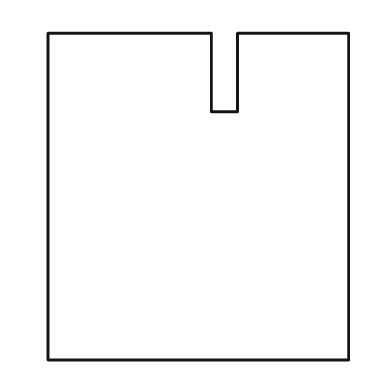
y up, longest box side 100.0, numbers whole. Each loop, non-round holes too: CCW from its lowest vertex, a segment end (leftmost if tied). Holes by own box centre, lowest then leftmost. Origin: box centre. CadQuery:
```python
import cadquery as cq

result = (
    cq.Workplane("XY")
    .moveTo(-46.0, -50.0)
    .lineTo(46.0, -50.0)
    .lineTo(46.0, 50.0)
    .lineTo(12.0, 50.0)
    .lineTo(12.0, 26.0)
    .lineTo(4.0, 26.0)
    .lineTo(4.0, 50.0)
    .lineTo(-46.0, 50.0)
    .close()
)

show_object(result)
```